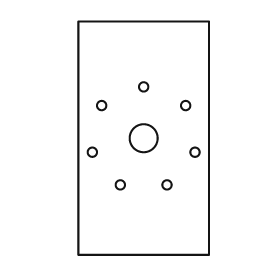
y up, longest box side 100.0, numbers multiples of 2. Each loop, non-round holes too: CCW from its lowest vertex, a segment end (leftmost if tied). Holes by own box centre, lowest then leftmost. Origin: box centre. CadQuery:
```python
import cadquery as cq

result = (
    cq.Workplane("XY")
    .moveTo(-28.0, -50.0)
    .lineTo(28.0, -50.0)
    .lineTo(28.0, 50.0)
    .lineTo(-28.0, 50.0)
    .close()
    .moveTo(-10.0, -20.0)
    .circle(2.0)
    .moveTo(10.0, -20.0)
    .circle(2.0)
    .moveTo(-22.0, -6.0)
    .circle(2.0)
    .moveTo(22.0, -6.0)
    .circle(2.0)
    .moveTo(0.0, 0.0)
    .circle(6.0)
    .moveTo(-18.0, 14.0)
    .circle(2.0)
    .moveTo(18.0, 14.0)
    .circle(2.0)
    .moveTo(0.0, 22.0)
    .circle(2.0)
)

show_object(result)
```